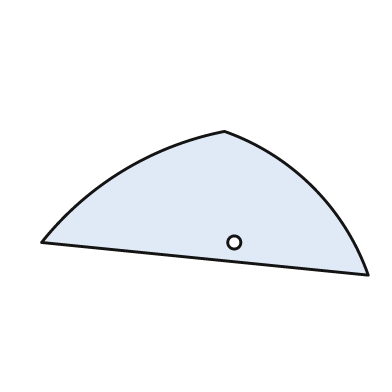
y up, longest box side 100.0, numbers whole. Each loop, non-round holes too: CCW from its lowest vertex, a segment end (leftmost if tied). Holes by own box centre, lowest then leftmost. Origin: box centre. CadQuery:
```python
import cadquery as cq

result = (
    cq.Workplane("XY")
    .moveTo(50.0, -22.0)
    .threePointArc((33.0, 5.0), (6.0, 22.0))
    .threePointArc((-25.0, 10.0), (-50.0, -12.0))
    .close()
    .moveTo(9.0, -12.0)
    .circle(2.0)
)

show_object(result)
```